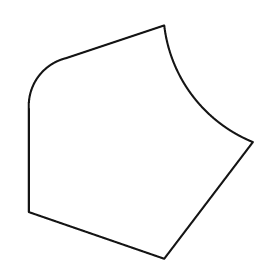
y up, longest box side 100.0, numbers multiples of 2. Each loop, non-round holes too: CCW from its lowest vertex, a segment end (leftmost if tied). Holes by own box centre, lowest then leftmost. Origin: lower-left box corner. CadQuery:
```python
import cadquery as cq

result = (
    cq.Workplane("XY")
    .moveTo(58.0, 0.0)
    .lineTo(96.0, 50.0)
    .threePointArc((70.0, 70.0), (58.0, 100.0))
    .lineTo(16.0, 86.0)
    .threePointArc((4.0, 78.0), (0.0, 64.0))
    .lineTo(0.0, 20.0)
    .close()
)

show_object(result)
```